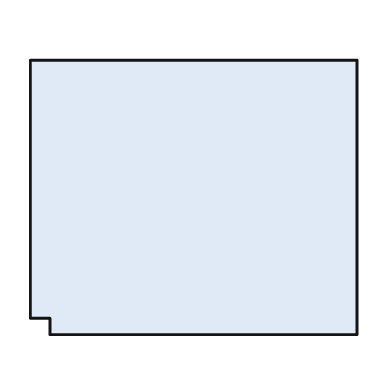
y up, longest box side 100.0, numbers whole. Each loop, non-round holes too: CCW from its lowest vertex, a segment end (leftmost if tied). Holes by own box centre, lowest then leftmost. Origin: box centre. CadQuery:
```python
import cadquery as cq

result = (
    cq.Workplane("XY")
    .moveTo(-44.0, -42.0)
    .lineTo(50.0, -42.0)
    .lineTo(50.0, 42.0)
    .lineTo(-50.0, 42.0)
    .lineTo(-50.0, -37.0)
    .lineTo(-44.0, -37.0)
    .close()
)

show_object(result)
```